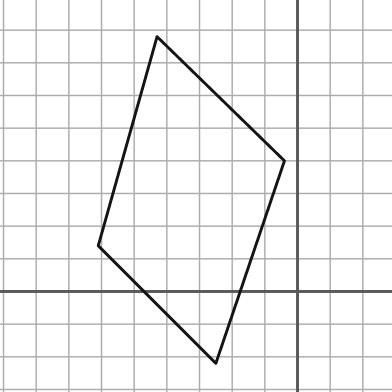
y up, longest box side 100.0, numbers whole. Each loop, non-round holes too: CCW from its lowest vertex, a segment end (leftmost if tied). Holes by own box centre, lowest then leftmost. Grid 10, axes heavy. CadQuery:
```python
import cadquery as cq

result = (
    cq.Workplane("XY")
    .moveTo(-25.0, -22.0)
    .lineTo(-4.0, 40.0)
    .lineTo(-43.0, 78.0)
    .lineTo(-61.0, 14.0)
    .close()
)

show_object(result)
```